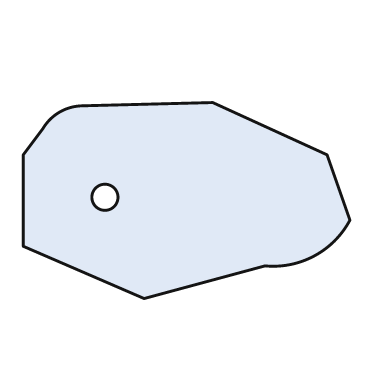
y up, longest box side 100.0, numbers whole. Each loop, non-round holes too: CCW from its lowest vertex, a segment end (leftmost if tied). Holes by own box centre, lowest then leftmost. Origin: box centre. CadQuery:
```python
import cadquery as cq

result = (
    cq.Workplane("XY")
    .moveTo(-13.0, -30.0)
    .lineTo(24.0, -20.0)
    .threePointArc((39.0, -17.0), (50.0, -6.0))
    .lineTo(43.0, 14.0)
    .lineTo(8.0, 30.0)
    .lineTo(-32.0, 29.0)
    .threePointArc((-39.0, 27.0), (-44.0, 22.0))
    .lineTo(-50.0, 14.0)
    .lineTo(-50.0, -14.0)
    .close()
    .moveTo(-25.0, 1.0)
    .circle(4.0)
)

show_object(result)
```